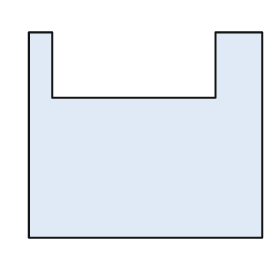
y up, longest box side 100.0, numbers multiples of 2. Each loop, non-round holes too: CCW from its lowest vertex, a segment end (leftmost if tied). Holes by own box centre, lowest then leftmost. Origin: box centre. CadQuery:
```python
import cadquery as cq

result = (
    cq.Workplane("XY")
    .moveTo(-50.0, -44.0)
    .lineTo(50.0, -44.0)
    .lineTo(50.0, 44.0)
    .lineTo(30.0, 44.0)
    .lineTo(30.0, 16.0)
    .lineTo(-40.0, 16.0)
    .lineTo(-40.0, 44.0)
    .lineTo(-50.0, 44.0)
    .close()
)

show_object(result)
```